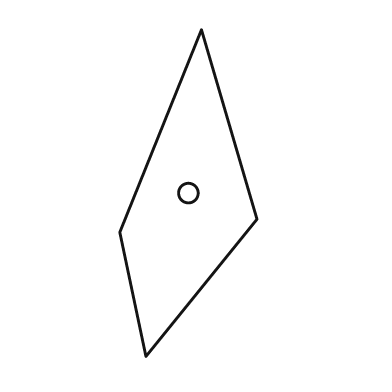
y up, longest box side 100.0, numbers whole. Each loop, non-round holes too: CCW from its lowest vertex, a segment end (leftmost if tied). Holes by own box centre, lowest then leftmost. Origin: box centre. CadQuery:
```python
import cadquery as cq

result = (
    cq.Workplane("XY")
    .moveTo(-13.0, -50.0)
    .lineTo(21.0, -8.0)
    .lineTo(4.0, 50.0)
    .lineTo(-21.0, -12.0)
    .close()
    .moveTo(0.0, 0.0)
    .circle(3.0)
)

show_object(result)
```